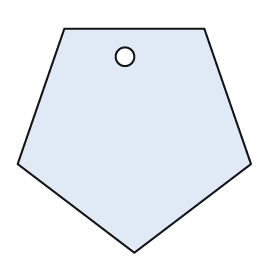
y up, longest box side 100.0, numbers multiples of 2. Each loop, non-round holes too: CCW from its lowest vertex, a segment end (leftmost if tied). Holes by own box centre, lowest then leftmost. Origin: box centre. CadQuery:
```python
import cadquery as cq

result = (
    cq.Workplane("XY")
    .moveTo(0.0, -48.0)
    .lineTo(50.0, -10.0)
    .lineTo(30.0, 48.0)
    .lineTo(-30.0, 48.0)
    .lineTo(-50.0, -10.0)
    .close()
    .moveTo(-4.0, 36.0)
    .circle(4.0)
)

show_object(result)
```